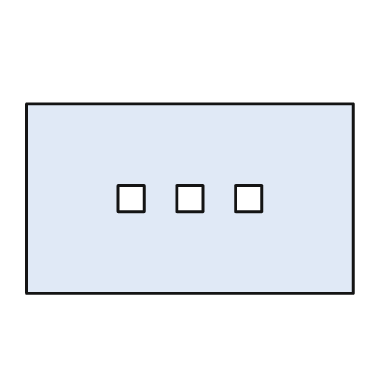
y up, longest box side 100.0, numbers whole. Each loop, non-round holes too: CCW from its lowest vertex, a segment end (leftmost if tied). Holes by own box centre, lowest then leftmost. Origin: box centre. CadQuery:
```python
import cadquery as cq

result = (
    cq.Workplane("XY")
    .moveTo(-50.0, -29.0)
    .lineTo(50.0, -29.0)
    .lineTo(50.0, 29.0)
    .lineTo(-50.0, 29.0)
    .close()
    .moveTo(-22.0, -4.0)
    .lineTo(-14.0, -4.0)
    .lineTo(-14.0, 4.0)
    .lineTo(-22.0, 4.0)
    .close()
    .moveTo(-4.0, -4.0)
    .lineTo(4.0, -4.0)
    .lineTo(4.0, 4.0)
    .lineTo(-4.0, 4.0)
    .close()
    .moveTo(14.0, -4.0)
    .lineTo(22.0, -4.0)
    .lineTo(22.0, 4.0)
    .lineTo(14.0, 4.0)
    .close()
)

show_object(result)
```